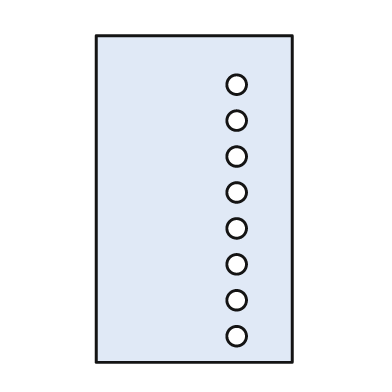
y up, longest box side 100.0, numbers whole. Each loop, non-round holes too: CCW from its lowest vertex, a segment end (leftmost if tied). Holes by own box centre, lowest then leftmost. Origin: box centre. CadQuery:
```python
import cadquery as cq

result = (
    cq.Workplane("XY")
    .moveTo(-30.0, -50.0)
    .lineTo(30.0, -50.0)
    .lineTo(30.0, 50.0)
    .lineTo(-30.0, 50.0)
    .close()
    .moveTo(13.0, -42.0)
    .circle(3.0)
    .moveTo(13.0, -31.0)
    .circle(3.0)
    .moveTo(13.0, -20.0)
    .circle(3.0)
    .moveTo(13.0, -9.0)
    .circle(3.0)
    .moveTo(13.0, 2.0)
    .circle(3.0)
    .moveTo(13.0, 13.0)
    .circle(3.0)
    .moveTo(13.0, 24.0)
    .circle(3.0)
    .moveTo(13.0, 35.0)
    .circle(3.0)
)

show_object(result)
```